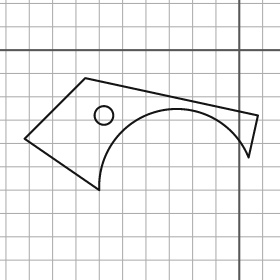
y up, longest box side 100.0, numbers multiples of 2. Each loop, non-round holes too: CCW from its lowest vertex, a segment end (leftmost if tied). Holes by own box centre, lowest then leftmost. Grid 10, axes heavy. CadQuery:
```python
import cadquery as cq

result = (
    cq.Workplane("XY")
    .moveTo(-60.0, -60.0)
    .threePointArc((-34.0, -26.0), (4.0, -46.0))
    .lineTo(8.0, -28.0)
    .lineTo(-66.0, -12.0)
    .lineTo(-92.0, -38.0)
    .close()
    .moveTo(-58.0, -28.0)
    .circle(4.0)
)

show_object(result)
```